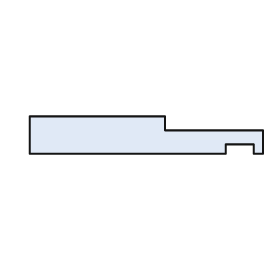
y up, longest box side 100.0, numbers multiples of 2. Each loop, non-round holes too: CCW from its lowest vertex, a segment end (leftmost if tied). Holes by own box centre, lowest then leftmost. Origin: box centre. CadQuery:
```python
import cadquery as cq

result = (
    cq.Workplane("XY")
    .moveTo(-50.0, -8.0)
    .lineTo(34.0, -8.0)
    .lineTo(34.0, -4.0)
    .lineTo(46.0, -4.0)
    .lineTo(46.0, -8.0)
    .lineTo(50.0, -8.0)
    .lineTo(50.0, 2.0)
    .lineTo(8.0, 2.0)
    .lineTo(8.0, 8.0)
    .lineTo(-50.0, 8.0)
    .close()
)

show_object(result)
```